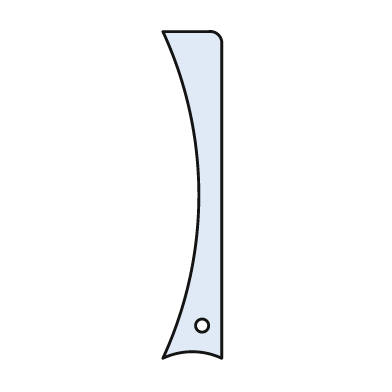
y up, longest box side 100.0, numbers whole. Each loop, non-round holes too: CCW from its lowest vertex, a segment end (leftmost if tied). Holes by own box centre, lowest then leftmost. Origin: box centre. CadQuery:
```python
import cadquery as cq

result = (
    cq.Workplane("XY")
    .moveTo(-9.0, -50.0)
    .threePointArc((0.0, -48.0), (9.0, -50.0))
    .lineTo(9.0, 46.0)
    .threePointArc((8.0, 49.0), (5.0, 50.0))
    .lineTo(-9.0, 50.0)
    .threePointArc((2.0, 0.0), (-9.0, -50.0))
    .close()
    .moveTo(3.0, -40.0)
    .circle(2.0)
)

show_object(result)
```